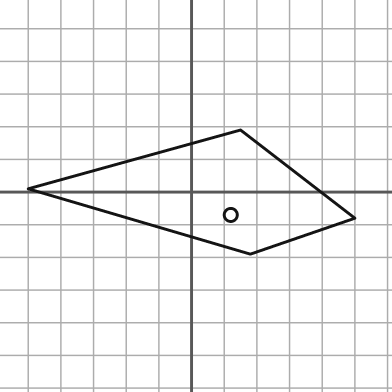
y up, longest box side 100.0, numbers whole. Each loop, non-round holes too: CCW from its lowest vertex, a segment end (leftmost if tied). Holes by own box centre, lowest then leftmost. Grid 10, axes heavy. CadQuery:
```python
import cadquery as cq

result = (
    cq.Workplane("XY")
    .moveTo(18.0, -19.0)
    .lineTo(50.0, -8.0)
    .lineTo(15.0, 19.0)
    .lineTo(-50.0, 1.0)
    .close()
    .moveTo(12.0, -7.0)
    .circle(2.0)
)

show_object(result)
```